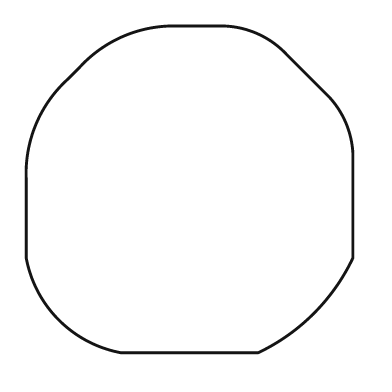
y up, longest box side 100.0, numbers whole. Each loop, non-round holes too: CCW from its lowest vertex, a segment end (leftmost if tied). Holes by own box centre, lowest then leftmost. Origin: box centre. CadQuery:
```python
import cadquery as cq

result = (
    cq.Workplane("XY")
    .moveTo(-21.0, -50.0)
    .lineTo(21.0, -50.0)
    .threePointArc((38.0, -38.0), (50.0, -21.0))
    .lineTo(50.0, 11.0)
    .threePointArc((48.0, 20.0), (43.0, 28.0))
    .lineTo(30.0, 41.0)
    .threePointArc((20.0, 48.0), (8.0, 50.0))
    .lineTo(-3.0, 50.0)
    .threePointArc((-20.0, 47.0), (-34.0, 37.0))
    .lineTo(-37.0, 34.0)
    .threePointArc((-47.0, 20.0), (-50.0, 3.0))
    .lineTo(-50.0, -21.0)
    .threePointArc((-40.0, -40.0), (-21.0, -50.0))
    .close()
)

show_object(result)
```